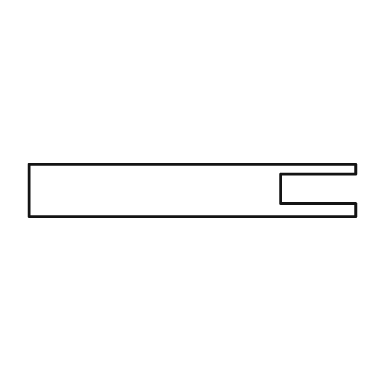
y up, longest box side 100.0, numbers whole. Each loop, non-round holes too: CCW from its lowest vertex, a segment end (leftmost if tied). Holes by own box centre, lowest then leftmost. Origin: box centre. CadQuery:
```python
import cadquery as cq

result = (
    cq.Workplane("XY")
    .moveTo(-50.0, -8.0)
    .lineTo(50.0, -8.0)
    .lineTo(50.0, -4.0)
    .lineTo(27.0, -4.0)
    .lineTo(27.0, 5.0)
    .lineTo(50.0, 5.0)
    .lineTo(50.0, 8.0)
    .lineTo(-50.0, 8.0)
    .close()
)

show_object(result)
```